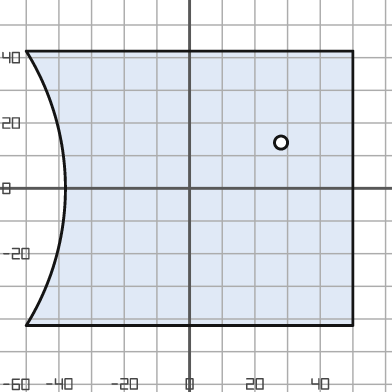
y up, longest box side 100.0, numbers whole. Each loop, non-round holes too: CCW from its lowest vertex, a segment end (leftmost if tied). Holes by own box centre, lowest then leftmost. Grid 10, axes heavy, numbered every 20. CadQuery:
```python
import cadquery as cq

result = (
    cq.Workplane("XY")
    .moveTo(-50.0, -42.0)
    .lineTo(50.0, -42.0)
    .lineTo(50.0, 42.0)
    .lineTo(-50.0, 42.0)
    .threePointArc((-38.0, 0.0), (-50.0, -42.0))
    .close()
    .moveTo(28.0, 14.0)
    .circle(2.0)
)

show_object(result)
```